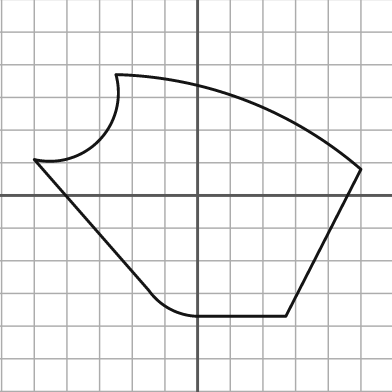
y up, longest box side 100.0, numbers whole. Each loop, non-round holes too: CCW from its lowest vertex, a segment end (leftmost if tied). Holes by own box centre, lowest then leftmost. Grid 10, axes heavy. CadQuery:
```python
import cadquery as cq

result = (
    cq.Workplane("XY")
    .moveTo(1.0, -37.0)
    .lineTo(27.0, -37.0)
    .lineTo(50.0, 8.0)
    .threePointArc((15.0, 29.0), (-25.0, 37.0))
    .threePointArc((-30.0, 17.0), (-50.0, 11.0))
    .lineTo(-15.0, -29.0)
    .threePointArc((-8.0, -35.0), (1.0, -37.0))
    .close()
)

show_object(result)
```